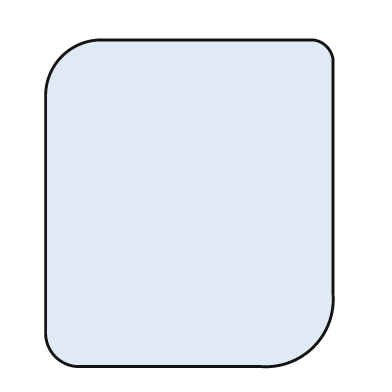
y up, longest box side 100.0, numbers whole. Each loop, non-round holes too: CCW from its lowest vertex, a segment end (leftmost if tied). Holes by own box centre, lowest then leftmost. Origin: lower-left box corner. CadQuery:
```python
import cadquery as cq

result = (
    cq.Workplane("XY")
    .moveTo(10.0, 0.0)
    .lineTo(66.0, 0.0)
    .threePointArc((82.0, 6.0), (88.0, 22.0))
    .lineTo(88.0, 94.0)
    .threePointArc((86.0, 98.0), (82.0, 100.0))
    .lineTo(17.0, 100.0)
    .threePointArc((5.0, 95.0), (0.0, 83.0))
    .lineTo(0.0, 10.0)
    .threePointArc((3.0, 3.0), (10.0, 0.0))
    .close()
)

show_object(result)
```